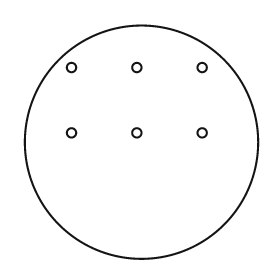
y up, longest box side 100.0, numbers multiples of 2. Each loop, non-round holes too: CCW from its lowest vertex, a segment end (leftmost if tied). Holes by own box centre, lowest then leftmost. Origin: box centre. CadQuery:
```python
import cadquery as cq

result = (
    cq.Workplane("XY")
    .moveTo(0.0, 0.0)
    .circle(50.0)
    .moveTo(-30.0, 4.0)
    .circle(2.0)
    .moveTo(-2.0, 4.0)
    .circle(2.0)
    .moveTo(26.0, 4.0)
    .circle(2.0)
    .moveTo(-30.0, 32.0)
    .circle(2.0)
    .moveTo(-2.0, 32.0)
    .circle(2.0)
    .moveTo(26.0, 32.0)
    .circle(2.0)
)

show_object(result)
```